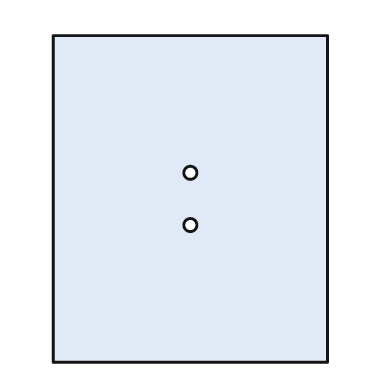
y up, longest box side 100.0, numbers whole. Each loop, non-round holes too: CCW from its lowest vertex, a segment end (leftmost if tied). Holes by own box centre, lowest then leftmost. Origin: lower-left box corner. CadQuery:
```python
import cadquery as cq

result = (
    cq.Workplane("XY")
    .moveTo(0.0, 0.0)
    .lineTo(84.0, 0.0)
    .lineTo(84.0, 100.0)
    .lineTo(0.0, 100.0)
    .close()
    .moveTo(42.0, 42.0)
    .circle(2.0)
    .moveTo(42.0, 58.0)
    .circle(2.0)
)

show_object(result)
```